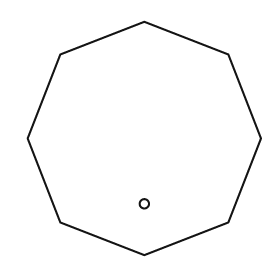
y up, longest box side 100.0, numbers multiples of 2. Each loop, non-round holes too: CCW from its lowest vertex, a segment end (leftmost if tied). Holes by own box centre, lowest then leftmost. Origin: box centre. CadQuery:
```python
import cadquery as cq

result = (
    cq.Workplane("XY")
    .moveTo(0.0, -50.0)
    .lineTo(36.0, -36.0)
    .lineTo(50.0, 0.0)
    .lineTo(36.0, 36.0)
    .lineTo(0.0, 50.0)
    .lineTo(-36.0, 36.0)
    .lineTo(-50.0, 0.0)
    .lineTo(-36.0, -36.0)
    .close()
    .moveTo(0.0, -28.0)
    .circle(2.0)
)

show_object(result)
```